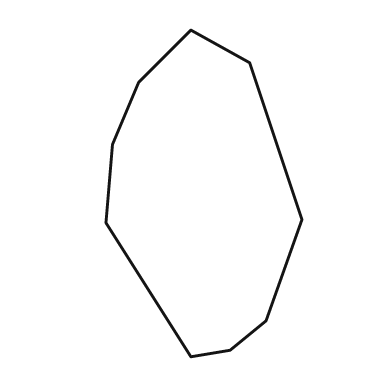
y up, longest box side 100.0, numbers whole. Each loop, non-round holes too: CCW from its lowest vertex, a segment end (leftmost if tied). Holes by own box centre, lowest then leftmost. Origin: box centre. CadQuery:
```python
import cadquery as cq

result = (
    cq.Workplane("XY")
    .moveTo(-4.0, -50.0)
    .lineTo(8.0, -48.0)
    .lineTo(19.0, -39.0)
    .lineTo(30.0, -8.0)
    .lineTo(14.0, 40.0)
    .lineTo(-4.0, 50.0)
    .lineTo(-20.0, 34.0)
    .lineTo(-28.0, 15.0)
    .lineTo(-30.0, -9.0)
    .close()
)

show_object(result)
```